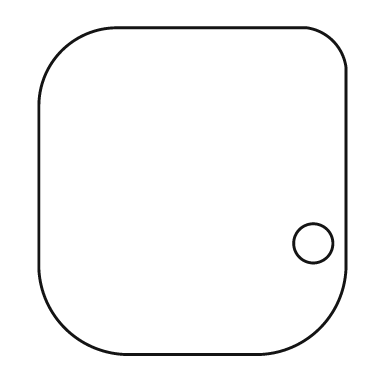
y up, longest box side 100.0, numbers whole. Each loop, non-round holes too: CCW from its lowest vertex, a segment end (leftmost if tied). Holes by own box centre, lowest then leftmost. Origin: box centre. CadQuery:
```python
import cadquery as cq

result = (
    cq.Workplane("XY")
    .moveTo(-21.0, -50.0)
    .lineTo(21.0, -50.0)
    .threePointArc((39.0, -42.0), (47.0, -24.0))
    .lineTo(47.0, 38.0)
    .threePointArc((43.0, 46.0), (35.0, 50.0))
    .lineTo(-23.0, 50.0)
    .threePointArc((-40.0, 43.0), (-47.0, 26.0))
    .lineTo(-47.0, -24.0)
    .threePointArc((-39.0, -42.0), (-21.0, -50.0))
    .close()
    .moveTo(37.0, -16.0)
    .circle(6.0)
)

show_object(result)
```